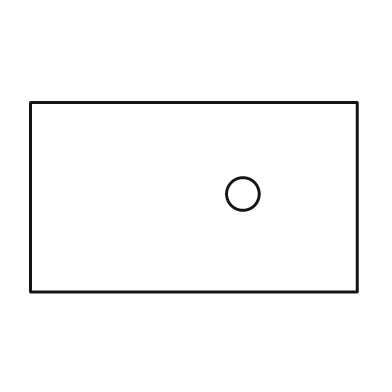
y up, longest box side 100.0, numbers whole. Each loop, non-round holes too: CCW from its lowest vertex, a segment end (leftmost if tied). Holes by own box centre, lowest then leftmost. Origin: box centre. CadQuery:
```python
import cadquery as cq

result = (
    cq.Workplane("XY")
    .moveTo(-50.0, -29.0)
    .lineTo(50.0, -29.0)
    .lineTo(50.0, 29.0)
    .lineTo(-50.0, 29.0)
    .close()
    .moveTo(15.0, 1.0)
    .circle(5.0)
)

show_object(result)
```